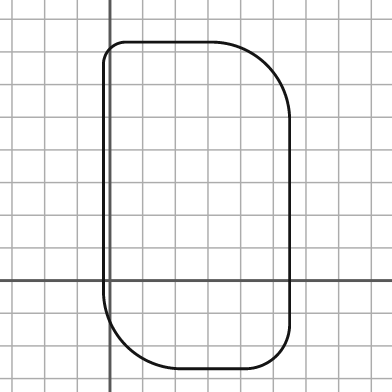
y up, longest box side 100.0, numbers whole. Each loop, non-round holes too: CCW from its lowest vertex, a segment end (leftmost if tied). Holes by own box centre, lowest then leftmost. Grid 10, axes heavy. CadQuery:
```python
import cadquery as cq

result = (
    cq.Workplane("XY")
    .moveTo(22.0, -27.0)
    .lineTo(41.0, -27.0)
    .threePointArc((51.0, -23.0), (55.0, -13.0))
    .lineTo(55.0, 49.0)
    .threePointArc((48.0, 66.0), (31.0, 73.0))
    .lineTo(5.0, 73.0)
    .threePointArc((0.0, 71.0), (-2.0, 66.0))
    .lineTo(-2.0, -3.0)
    .threePointArc((5.0, -20.0), (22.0, -27.0))
    .close()
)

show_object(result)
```